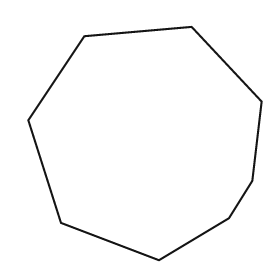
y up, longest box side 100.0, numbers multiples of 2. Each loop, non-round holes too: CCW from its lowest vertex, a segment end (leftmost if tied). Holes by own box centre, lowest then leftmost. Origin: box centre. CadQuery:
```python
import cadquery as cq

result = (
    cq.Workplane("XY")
    .moveTo(6.0, -50.0)
    .lineTo(36.0, -32.0)
    .lineTo(46.0, -16.0)
    .lineTo(50.0, 18.0)
    .lineTo(20.0, 50.0)
    .lineTo(-26.0, 46.0)
    .lineTo(-50.0, 10.0)
    .lineTo(-36.0, -34.0)
    .close()
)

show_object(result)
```